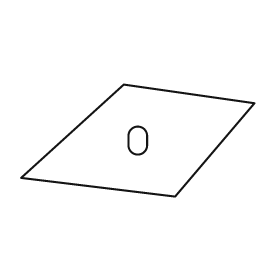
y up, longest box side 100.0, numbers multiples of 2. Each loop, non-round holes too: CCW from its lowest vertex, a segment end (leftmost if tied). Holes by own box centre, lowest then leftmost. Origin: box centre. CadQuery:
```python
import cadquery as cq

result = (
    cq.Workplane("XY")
    .moveTo(16.0, -24.0)
    .lineTo(50.0, 16.0)
    .lineTo(-6.0, 24.0)
    .lineTo(-50.0, -16.0)
    .close()
    .moveTo(-4.0, -2.0)
    .threePointArc((0.0, -6.0), (4.0, -2.0))
    .lineTo(4.0, 2.0)
    .threePointArc((0.0, 6.0), (-4.0, 2.0))
    .close()
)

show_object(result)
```